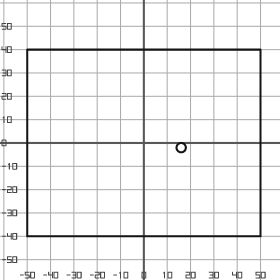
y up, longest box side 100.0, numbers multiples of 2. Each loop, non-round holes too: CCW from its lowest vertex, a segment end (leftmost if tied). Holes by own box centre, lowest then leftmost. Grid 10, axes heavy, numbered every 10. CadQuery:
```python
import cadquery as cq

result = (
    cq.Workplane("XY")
    .moveTo(-50.0, -40.0)
    .lineTo(50.0, -40.0)
    .lineTo(50.0, 40.0)
    .lineTo(-50.0, 40.0)
    .close()
    .moveTo(16.0, -2.0)
    .circle(2.0)
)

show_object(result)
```